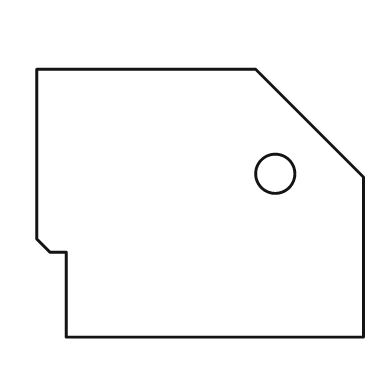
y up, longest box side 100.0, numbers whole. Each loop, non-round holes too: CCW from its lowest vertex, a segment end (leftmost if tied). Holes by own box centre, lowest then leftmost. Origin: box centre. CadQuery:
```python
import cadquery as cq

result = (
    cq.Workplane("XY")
    .moveTo(-41.0, -41.0)
    .lineTo(50.0, -41.0)
    .lineTo(50.0, 8.0)
    .lineTo(17.0, 41.0)
    .lineTo(-50.0, 41.0)
    .lineTo(-50.0, -11.0)
    .lineTo(-46.0, -15.0)
    .lineTo(-41.0, -15.0)
    .close()
    .moveTo(23.0, 9.0)
    .circle(6.0)
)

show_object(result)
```